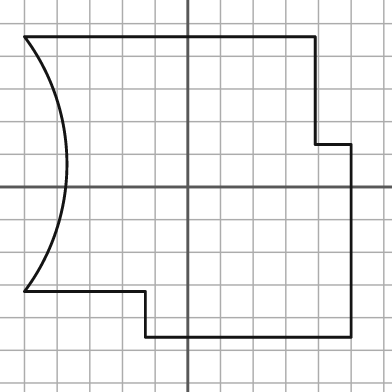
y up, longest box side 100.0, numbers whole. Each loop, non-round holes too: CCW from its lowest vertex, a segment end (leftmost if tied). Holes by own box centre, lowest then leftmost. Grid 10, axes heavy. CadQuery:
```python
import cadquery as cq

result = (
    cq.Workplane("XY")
    .moveTo(-13.0, -46.0)
    .lineTo(50.0, -46.0)
    .lineTo(50.0, 13.0)
    .lineTo(39.0, 13.0)
    .lineTo(39.0, 46.0)
    .lineTo(-50.0, 46.0)
    .threePointArc((-37.0, 7.0), (-50.0, -32.0))
    .lineTo(-13.0, -32.0)
    .close()
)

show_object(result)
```